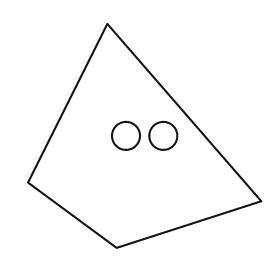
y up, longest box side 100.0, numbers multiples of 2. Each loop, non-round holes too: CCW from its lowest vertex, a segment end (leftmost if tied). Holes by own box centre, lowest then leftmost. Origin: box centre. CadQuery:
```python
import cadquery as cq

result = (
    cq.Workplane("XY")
    .moveTo(-12.0, -48.0)
    .lineTo(50.0, -28.0)
    .lineTo(-16.0, 48.0)
    .lineTo(-50.0, -20.0)
    .close()
    .moveTo(-8.0, 0.0)
    .circle(6.0)
    .moveTo(8.0, 0.0)
    .circle(6.0)
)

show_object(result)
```